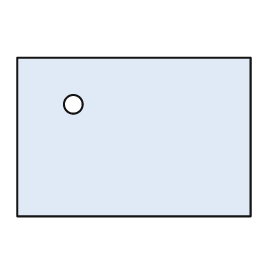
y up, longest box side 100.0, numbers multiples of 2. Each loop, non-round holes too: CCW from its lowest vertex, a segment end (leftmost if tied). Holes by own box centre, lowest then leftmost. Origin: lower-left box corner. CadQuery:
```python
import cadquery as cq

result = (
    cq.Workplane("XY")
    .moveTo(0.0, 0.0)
    .lineTo(100.0, 0.0)
    .lineTo(100.0, 68.0)
    .lineTo(0.0, 68.0)
    .close()
    .moveTo(24.0, 48.0)
    .circle(4.0)
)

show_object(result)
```